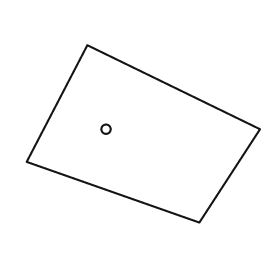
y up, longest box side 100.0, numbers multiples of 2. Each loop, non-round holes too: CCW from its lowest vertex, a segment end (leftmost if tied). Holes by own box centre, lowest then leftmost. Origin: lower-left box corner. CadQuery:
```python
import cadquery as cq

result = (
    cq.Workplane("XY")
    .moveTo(74.0, 0.0)
    .lineTo(100.0, 40.0)
    .lineTo(26.0, 76.0)
    .lineTo(0.0, 26.0)
    .close()
    .moveTo(34.0, 40.0)
    .circle(2.0)
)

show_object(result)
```